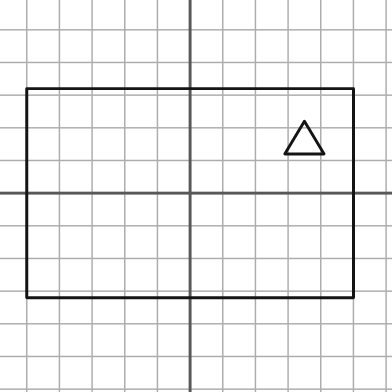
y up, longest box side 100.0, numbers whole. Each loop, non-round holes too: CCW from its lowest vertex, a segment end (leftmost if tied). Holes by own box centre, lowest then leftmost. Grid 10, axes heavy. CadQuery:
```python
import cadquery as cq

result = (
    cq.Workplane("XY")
    .moveTo(-50.0, -32.0)
    .lineTo(50.0, -32.0)
    .lineTo(50.0, 32.0)
    .lineTo(-50.0, 32.0)
    .close()
    .moveTo(29.0, 12.0)
    .lineTo(41.0, 12.0)
    .lineTo(35.0, 22.0)
    .close()
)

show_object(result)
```